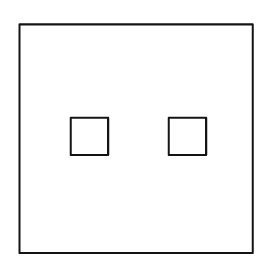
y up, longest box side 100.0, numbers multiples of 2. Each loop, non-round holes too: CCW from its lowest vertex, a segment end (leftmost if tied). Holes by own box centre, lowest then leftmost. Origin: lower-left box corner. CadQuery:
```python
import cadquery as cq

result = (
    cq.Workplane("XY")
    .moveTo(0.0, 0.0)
    .lineTo(100.0, 0.0)
    .lineTo(100.0, 98.0)
    .lineTo(0.0, 98.0)
    .close()
    .moveTo(22.0, 42.0)
    .lineTo(38.0, 42.0)
    .lineTo(38.0, 58.0)
    .lineTo(22.0, 58.0)
    .close()
    .moveTo(64.0, 42.0)
    .lineTo(80.0, 42.0)
    .lineTo(80.0, 58.0)
    .lineTo(64.0, 58.0)
    .close()
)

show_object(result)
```